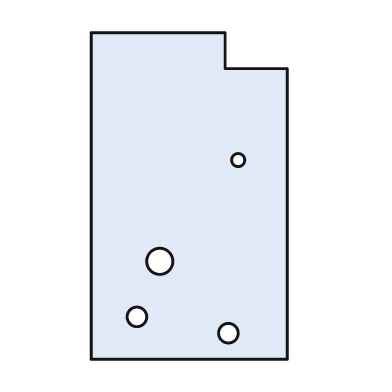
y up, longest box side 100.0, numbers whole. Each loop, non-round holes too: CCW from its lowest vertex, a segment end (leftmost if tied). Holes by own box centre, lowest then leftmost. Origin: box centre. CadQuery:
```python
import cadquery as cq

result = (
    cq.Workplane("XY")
    .moveTo(-30.0, -50.0)
    .lineTo(30.0, -50.0)
    .lineTo(30.0, 39.0)
    .lineTo(11.0, 39.0)
    .lineTo(11.0, 50.0)
    .lineTo(-30.0, 50.0)
    .close()
    .moveTo(12.0, -42.0)
    .circle(3.0)
    .moveTo(-16.0, -37.0)
    .circle(3.0)
    .moveTo(-9.0, -20.0)
    .circle(4.0)
    .moveTo(15.0, 11.0)
    .circle(2.0)
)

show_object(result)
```